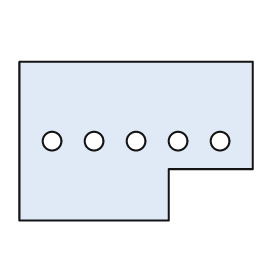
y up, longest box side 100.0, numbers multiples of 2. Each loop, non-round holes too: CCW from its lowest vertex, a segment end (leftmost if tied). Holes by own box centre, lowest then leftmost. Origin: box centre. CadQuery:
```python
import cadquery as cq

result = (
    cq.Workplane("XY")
    .moveTo(-50.0, -34.0)
    .lineTo(14.0, -34.0)
    .lineTo(14.0, -12.0)
    .lineTo(50.0, -12.0)
    .lineTo(50.0, 34.0)
    .lineTo(-50.0, 34.0)
    .close()
    .moveTo(-36.0, 0.0)
    .circle(4.0)
    .moveTo(-18.0, 0.0)
    .circle(4.0)
    .moveTo(0.0, 0.0)
    .circle(4.0)
    .moveTo(18.0, 0.0)
    .circle(4.0)
    .moveTo(36.0, 0.0)
    .circle(4.0)
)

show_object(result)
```